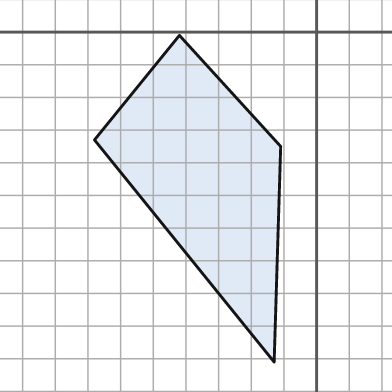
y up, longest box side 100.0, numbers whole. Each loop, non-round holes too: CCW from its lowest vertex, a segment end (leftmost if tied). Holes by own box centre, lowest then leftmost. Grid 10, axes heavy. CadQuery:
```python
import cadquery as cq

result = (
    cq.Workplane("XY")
    .moveTo(-13.0, -101.0)
    .lineTo(-11.0, -35.0)
    .lineTo(-42.0, -1.0)
    .lineTo(-68.0, -33.0)
    .close()
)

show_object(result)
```